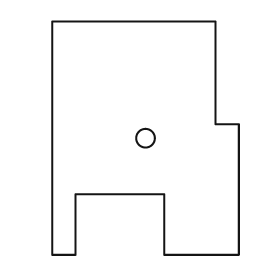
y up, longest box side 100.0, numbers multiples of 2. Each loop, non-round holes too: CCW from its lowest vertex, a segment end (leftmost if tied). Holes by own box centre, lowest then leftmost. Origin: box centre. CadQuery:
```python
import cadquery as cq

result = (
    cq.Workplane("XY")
    .moveTo(-40.0, -50.0)
    .lineTo(-30.0, -50.0)
    .lineTo(-30.0, -24.0)
    .lineTo(8.0, -24.0)
    .lineTo(8.0, -50.0)
    .lineTo(40.0, -50.0)
    .lineTo(40.0, 6.0)
    .lineTo(30.0, 6.0)
    .lineTo(30.0, 50.0)
    .lineTo(-40.0, 50.0)
    .close()
    .moveTo(0.0, 0.0)
    .circle(4.0)
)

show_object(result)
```